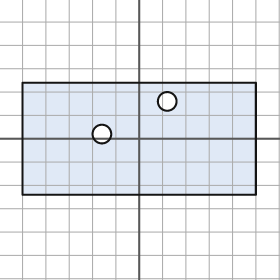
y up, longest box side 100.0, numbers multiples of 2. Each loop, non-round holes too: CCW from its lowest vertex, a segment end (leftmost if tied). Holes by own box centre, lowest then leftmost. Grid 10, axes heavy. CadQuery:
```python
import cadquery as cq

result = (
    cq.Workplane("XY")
    .moveTo(-50.0, -24.0)
    .lineTo(50.0, -24.0)
    .lineTo(50.0, 24.0)
    .lineTo(-50.0, 24.0)
    .close()
    .moveTo(-16.0, 2.0)
    .circle(4.0)
    .moveTo(12.0, 16.0)
    .circle(4.0)
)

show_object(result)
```